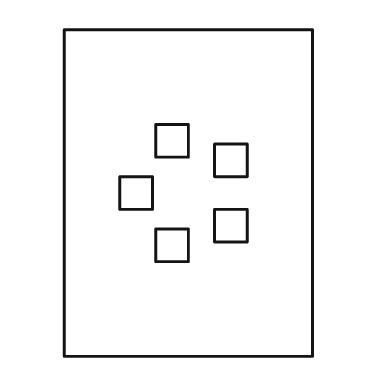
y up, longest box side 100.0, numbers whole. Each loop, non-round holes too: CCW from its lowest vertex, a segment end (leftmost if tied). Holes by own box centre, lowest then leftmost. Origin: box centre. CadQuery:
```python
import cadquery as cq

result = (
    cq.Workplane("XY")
    .moveTo(-38.0, -50.0)
    .lineTo(38.0, -50.0)
    .lineTo(38.0, 50.0)
    .lineTo(-38.0, 50.0)
    .close()
    .moveTo(-10.0, -21.0)
    .lineTo(0.0, -21.0)
    .lineTo(0.0, -11.0)
    .lineTo(-10.0, -11.0)
    .close()
    .moveTo(8.0, -15.0)
    .lineTo(18.0, -15.0)
    .lineTo(18.0, -5.0)
    .lineTo(8.0, -5.0)
    .close()
    .moveTo(-21.0, -5.0)
    .lineTo(-11.0, -5.0)
    .lineTo(-11.0, 5.0)
    .lineTo(-21.0, 5.0)
    .close()
    .moveTo(8.0, 5.0)
    .lineTo(18.0, 5.0)
    .lineTo(18.0, 15.0)
    .lineTo(8.0, 15.0)
    .close()
    .moveTo(-10.0, 11.0)
    .lineTo(0.0, 11.0)
    .lineTo(0.0, 21.0)
    .lineTo(-10.0, 21.0)
    .close()
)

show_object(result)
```